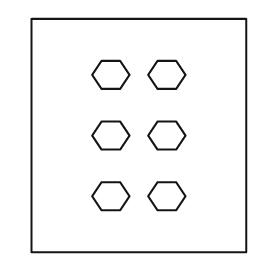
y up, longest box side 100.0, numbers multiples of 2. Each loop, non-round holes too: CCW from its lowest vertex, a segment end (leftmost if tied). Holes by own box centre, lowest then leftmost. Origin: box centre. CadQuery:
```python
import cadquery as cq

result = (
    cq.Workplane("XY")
    .moveTo(-46.0, -50.0)
    .lineTo(46.0, -50.0)
    .lineTo(46.0, 50.0)
    .lineTo(-46.0, 50.0)
    .close()
    .moveTo(-16.0, -32.0)
    .lineTo(-8.0, -32.0)
    .lineTo(-4.0, -26.0)
    .lineTo(-8.0, -20.0)
    .lineTo(-16.0, -20.0)
    .lineTo(-20.0, -26.0)
    .close()
    .moveTo(8.0, -32.0)
    .lineTo(16.0, -32.0)
    .lineTo(20.0, -26.0)
    .lineTo(16.0, -20.0)
    .lineTo(8.0, -20.0)
    .lineTo(4.0, -26.0)
    .close()
    .moveTo(-16.0, -6.0)
    .lineTo(-8.0, -6.0)
    .lineTo(-4.0, 0.0)
    .lineTo(-8.0, 6.0)
    .lineTo(-16.0, 6.0)
    .lineTo(-20.0, 0.0)
    .close()
    .moveTo(8.0, -6.0)
    .lineTo(16.0, -6.0)
    .lineTo(20.0, 0.0)
    .lineTo(16.0, 6.0)
    .lineTo(8.0, 6.0)
    .lineTo(4.0, 0.0)
    .close()
    .moveTo(-16.0, 20.0)
    .lineTo(-8.0, 20.0)
    .lineTo(-4.0, 26.0)
    .lineTo(-8.0, 32.0)
    .lineTo(-16.0, 32.0)
    .lineTo(-20.0, 26.0)
    .close()
    .moveTo(8.0, 20.0)
    .lineTo(16.0, 20.0)
    .lineTo(20.0, 26.0)
    .lineTo(16.0, 32.0)
    .lineTo(8.0, 32.0)
    .lineTo(4.0, 26.0)
    .close()
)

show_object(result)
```